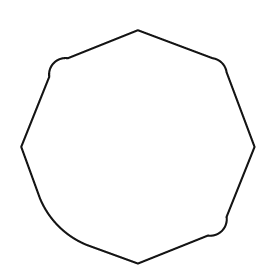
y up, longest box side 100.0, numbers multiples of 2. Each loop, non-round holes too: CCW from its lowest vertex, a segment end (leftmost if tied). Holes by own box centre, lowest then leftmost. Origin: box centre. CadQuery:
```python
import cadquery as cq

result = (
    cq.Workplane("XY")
    .moveTo(0.0, -50.0)
    .lineTo(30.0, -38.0)
    .threePointArc((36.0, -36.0), (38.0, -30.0))
    .lineTo(50.0, 0.0)
    .lineTo(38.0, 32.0)
    .threePointArc((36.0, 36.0), (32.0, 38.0))
    .lineTo(0.0, 50.0)
    .lineTo(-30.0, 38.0)
    .threePointArc((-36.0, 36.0), (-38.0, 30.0))
    .lineTo(-50.0, 0.0)
    .lineTo(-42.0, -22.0)
    .threePointArc((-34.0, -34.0), (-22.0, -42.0))
    .close()
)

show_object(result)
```